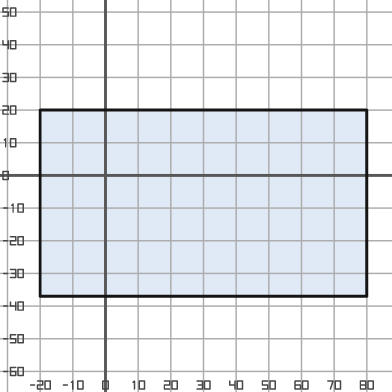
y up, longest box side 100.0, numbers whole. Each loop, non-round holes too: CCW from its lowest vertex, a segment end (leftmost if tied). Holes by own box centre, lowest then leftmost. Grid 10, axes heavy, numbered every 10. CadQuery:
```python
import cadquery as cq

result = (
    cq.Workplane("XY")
    .moveTo(-20.0, -37.0)
    .lineTo(80.0, -37.0)
    .lineTo(80.0, 20.0)
    .lineTo(-20.0, 20.0)
    .close()
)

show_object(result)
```